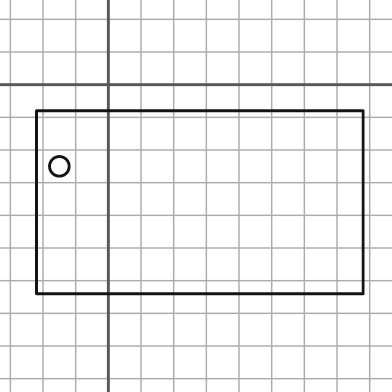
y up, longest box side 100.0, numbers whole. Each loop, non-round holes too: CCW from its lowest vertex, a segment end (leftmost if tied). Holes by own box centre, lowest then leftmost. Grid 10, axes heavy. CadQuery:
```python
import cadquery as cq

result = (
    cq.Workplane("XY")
    .moveTo(-22.0, -64.0)
    .lineTo(78.0, -64.0)
    .lineTo(78.0, -8.0)
    .lineTo(-22.0, -8.0)
    .close()
    .moveTo(-15.0, -25.0)
    .circle(3.0)
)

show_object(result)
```